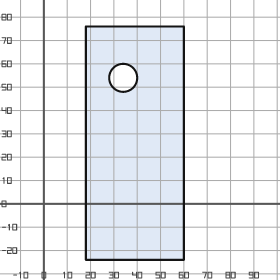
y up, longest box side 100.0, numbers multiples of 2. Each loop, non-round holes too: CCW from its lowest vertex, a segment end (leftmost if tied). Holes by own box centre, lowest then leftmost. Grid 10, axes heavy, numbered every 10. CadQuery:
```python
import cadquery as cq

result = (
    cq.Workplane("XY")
    .moveTo(18.0, -24.0)
    .lineTo(60.0, -24.0)
    .lineTo(60.0, 76.0)
    .lineTo(18.0, 76.0)
    .close()
    .moveTo(34.0, 54.0)
    .circle(6.0)
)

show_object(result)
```